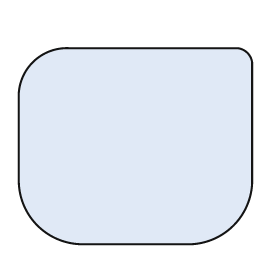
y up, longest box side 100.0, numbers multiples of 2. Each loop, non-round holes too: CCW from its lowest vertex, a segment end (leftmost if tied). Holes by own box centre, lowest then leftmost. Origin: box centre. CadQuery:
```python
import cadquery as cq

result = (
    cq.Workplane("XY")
    .moveTo(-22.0, -42.0)
    .lineTo(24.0, -42.0)
    .threePointArc((42.0, -34.0), (50.0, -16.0))
    .lineTo(50.0, 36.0)
    .threePointArc((48.0, 40.0), (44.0, 42.0))
    .lineTo(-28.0, 42.0)
    .threePointArc((-44.0, 36.0), (-50.0, 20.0))
    .lineTo(-50.0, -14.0)
    .threePointArc((-42.0, -34.0), (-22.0, -42.0))
    .close()
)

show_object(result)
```